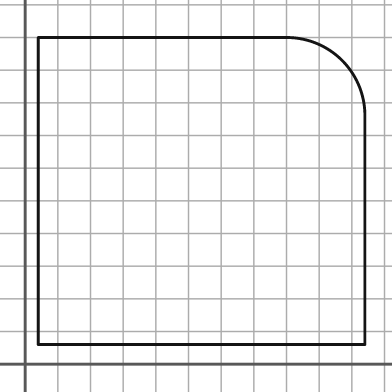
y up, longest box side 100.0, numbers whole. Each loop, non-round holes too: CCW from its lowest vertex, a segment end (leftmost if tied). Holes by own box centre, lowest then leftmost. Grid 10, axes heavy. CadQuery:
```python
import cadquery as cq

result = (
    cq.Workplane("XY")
    .moveTo(4.0, 6.0)
    .lineTo(104.0, 6.0)
    .lineTo(104.0, 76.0)
    .threePointArc((97.0, 93.0), (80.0, 100.0))
    .lineTo(4.0, 100.0)
    .close()
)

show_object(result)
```